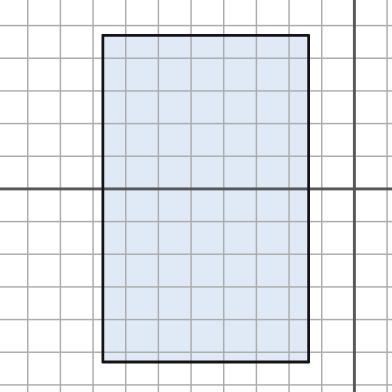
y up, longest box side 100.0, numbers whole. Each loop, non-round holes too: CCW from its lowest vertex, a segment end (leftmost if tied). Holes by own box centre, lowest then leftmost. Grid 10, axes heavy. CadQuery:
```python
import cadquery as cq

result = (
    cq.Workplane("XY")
    .moveTo(-77.0, -53.0)
    .lineTo(-14.0, -53.0)
    .lineTo(-14.0, 47.0)
    .lineTo(-77.0, 47.0)
    .close()
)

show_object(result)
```